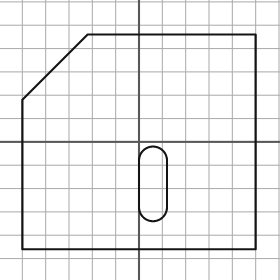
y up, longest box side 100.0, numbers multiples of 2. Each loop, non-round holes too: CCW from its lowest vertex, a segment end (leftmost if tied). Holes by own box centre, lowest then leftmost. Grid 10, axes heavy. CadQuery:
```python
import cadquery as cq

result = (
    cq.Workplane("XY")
    .moveTo(-50.0, -46.0)
    .lineTo(50.0, -46.0)
    .lineTo(50.0, 46.0)
    .lineTo(-22.0, 46.0)
    .lineTo(-50.0, 18.0)
    .close()
    .moveTo(0.0, -28.0)
    .threePointArc((6.0, -34.0), (12.0, -28.0))
    .lineTo(12.0, -8.0)
    .threePointArc((6.0, -2.0), (0.0, -8.0))
    .close()
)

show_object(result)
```